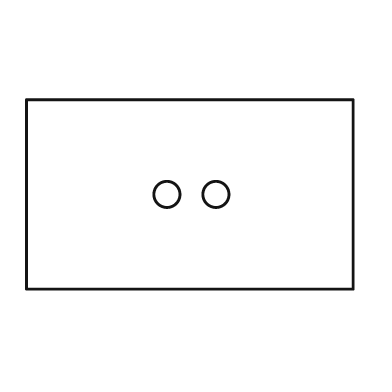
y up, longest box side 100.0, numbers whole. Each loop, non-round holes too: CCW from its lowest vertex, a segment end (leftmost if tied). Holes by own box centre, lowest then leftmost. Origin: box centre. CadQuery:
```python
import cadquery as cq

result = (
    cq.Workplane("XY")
    .moveTo(-50.0, -29.0)
    .lineTo(50.0, -29.0)
    .lineTo(50.0, 29.0)
    .lineTo(-50.0, 29.0)
    .close()
    .moveTo(-7.0, 0.0)
    .circle(4.0)
    .moveTo(8.0, 0.0)
    .circle(4.0)
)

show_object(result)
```